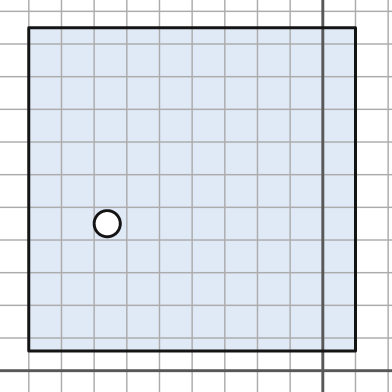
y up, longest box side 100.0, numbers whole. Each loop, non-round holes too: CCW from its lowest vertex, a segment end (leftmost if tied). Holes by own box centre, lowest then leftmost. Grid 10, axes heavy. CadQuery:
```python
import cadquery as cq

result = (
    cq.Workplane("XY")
    .moveTo(-90.0, 6.0)
    .lineTo(10.0, 6.0)
    .lineTo(10.0, 105.0)
    .lineTo(-90.0, 105.0)
    .close()
    .moveTo(-66.0, 45.0)
    .circle(4.0)
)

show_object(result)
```